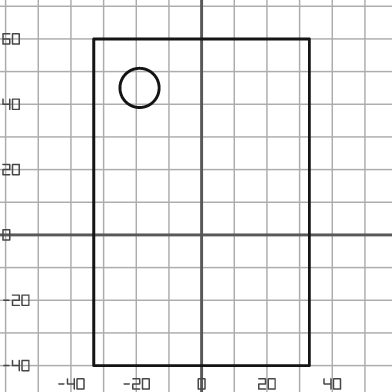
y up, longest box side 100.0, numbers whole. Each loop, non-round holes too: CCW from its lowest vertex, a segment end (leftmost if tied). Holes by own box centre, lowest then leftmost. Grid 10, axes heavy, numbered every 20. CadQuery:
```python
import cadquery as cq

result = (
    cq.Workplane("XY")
    .moveTo(-33.0, -40.0)
    .lineTo(33.0, -40.0)
    .lineTo(33.0, 60.0)
    .lineTo(-33.0, 60.0)
    .close()
    .moveTo(-19.0, 45.0)
    .circle(6.0)
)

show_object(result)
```